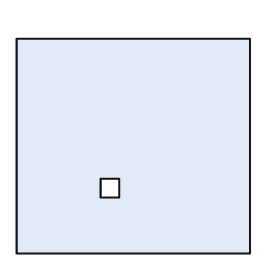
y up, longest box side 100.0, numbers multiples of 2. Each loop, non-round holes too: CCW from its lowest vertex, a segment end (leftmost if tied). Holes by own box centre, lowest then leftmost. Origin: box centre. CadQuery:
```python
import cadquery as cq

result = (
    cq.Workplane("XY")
    .moveTo(-50.0, -46.0)
    .lineTo(50.0, -46.0)
    .lineTo(50.0, 46.0)
    .lineTo(-50.0, 46.0)
    .close()
    .moveTo(-14.0, -22.0)
    .lineTo(-6.0, -22.0)
    .lineTo(-6.0, -14.0)
    .lineTo(-14.0, -14.0)
    .close()
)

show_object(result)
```